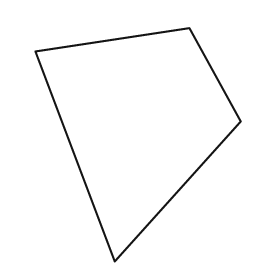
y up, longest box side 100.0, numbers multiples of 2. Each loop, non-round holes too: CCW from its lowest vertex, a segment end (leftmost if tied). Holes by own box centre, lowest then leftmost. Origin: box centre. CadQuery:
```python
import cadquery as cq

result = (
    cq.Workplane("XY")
    .moveTo(-10.0, -50.0)
    .lineTo(44.0, 10.0)
    .lineTo(22.0, 50.0)
    .lineTo(-44.0, 40.0)
    .close()
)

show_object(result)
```